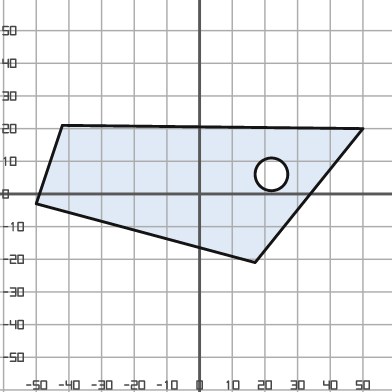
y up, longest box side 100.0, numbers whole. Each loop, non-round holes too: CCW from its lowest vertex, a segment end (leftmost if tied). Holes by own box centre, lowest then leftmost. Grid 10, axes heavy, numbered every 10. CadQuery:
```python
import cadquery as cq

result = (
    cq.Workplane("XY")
    .moveTo(17.0, -21.0)
    .lineTo(50.0, 20.0)
    .lineTo(-42.0, 21.0)
    .lineTo(-50.0, -3.0)
    .close()
    .moveTo(22.0, 6.0)
    .circle(5.0)
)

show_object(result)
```